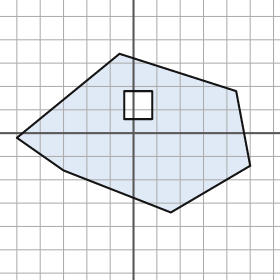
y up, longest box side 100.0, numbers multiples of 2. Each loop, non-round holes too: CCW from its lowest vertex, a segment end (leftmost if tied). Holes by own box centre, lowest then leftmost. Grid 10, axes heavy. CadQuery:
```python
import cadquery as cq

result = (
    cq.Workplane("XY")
    .moveTo(16.0, -34.0)
    .lineTo(50.0, -14.0)
    .lineTo(44.0, 18.0)
    .lineTo(-6.0, 34.0)
    .lineTo(-50.0, -2.0)
    .lineTo(-30.0, -16.0)
    .close()
    .moveTo(-4.0, 6.0)
    .lineTo(8.0, 6.0)
    .lineTo(8.0, 18.0)
    .lineTo(-4.0, 18.0)
    .close()
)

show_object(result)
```